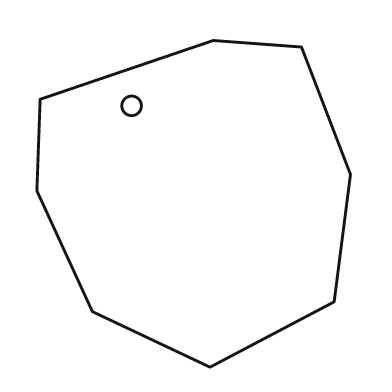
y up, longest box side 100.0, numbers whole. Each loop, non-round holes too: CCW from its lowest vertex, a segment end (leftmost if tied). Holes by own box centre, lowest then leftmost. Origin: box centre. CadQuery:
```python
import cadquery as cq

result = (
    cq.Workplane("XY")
    .moveTo(5.0, -50.0)
    .lineTo(43.0, -30.0)
    .lineTo(48.0, 9.0)
    .lineTo(33.0, 48.0)
    .lineTo(6.0, 50.0)
    .lineTo(-47.0, 32.0)
    .lineTo(-48.0, 4.0)
    .lineTo(-31.0, -33.0)
    .close()
    .moveTo(-19.0, 30.0)
    .circle(3.0)
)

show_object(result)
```